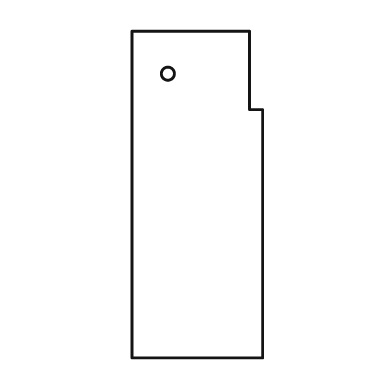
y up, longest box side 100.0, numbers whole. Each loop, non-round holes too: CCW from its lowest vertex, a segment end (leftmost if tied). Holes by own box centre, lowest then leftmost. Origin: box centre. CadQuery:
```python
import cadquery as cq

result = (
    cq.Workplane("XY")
    .moveTo(-20.0, -50.0)
    .lineTo(20.0, -50.0)
    .lineTo(20.0, 26.0)
    .lineTo(16.0, 26.0)
    .lineTo(16.0, 50.0)
    .lineTo(-20.0, 50.0)
    .close()
    .moveTo(-9.0, 37.0)
    .circle(2.0)
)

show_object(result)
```